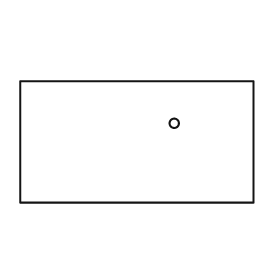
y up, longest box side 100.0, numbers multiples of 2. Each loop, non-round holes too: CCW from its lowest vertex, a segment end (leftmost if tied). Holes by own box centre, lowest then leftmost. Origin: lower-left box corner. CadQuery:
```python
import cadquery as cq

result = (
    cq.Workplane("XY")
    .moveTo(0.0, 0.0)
    .lineTo(100.0, 0.0)
    .lineTo(100.0, 52.0)
    .lineTo(0.0, 52.0)
    .close()
    .moveTo(66.0, 34.0)
    .circle(2.0)
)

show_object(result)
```